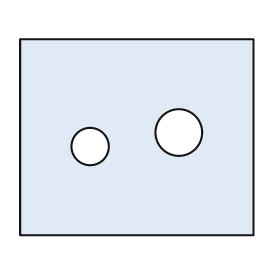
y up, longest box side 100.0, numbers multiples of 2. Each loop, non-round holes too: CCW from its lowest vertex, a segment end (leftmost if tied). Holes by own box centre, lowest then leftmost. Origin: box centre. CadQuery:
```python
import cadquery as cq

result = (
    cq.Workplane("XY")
    .moveTo(-50.0, -42.0)
    .lineTo(50.0, -42.0)
    .lineTo(50.0, 42.0)
    .lineTo(-50.0, 42.0)
    .close()
    .moveTo(-20.0, -4.0)
    .circle(8.0)
    .moveTo(18.0, 2.0)
    .circle(10.0)
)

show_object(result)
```